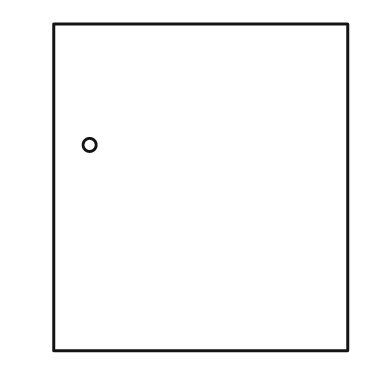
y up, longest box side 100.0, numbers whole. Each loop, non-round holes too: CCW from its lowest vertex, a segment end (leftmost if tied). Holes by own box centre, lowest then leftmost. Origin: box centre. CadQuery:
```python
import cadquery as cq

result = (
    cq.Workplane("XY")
    .moveTo(-45.0, -50.0)
    .lineTo(45.0, -50.0)
    .lineTo(45.0, 50.0)
    .lineTo(-45.0, 50.0)
    .close()
    .moveTo(-34.0, 13.0)
    .circle(2.0)
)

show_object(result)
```